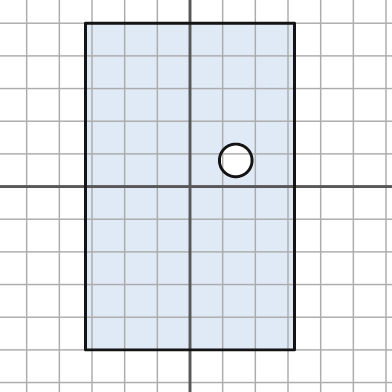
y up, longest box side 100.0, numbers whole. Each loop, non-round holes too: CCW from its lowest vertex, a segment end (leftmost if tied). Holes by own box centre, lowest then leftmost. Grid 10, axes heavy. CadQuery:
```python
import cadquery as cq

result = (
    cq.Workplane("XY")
    .moveTo(-32.0, -50.0)
    .lineTo(32.0, -50.0)
    .lineTo(32.0, 50.0)
    .lineTo(-32.0, 50.0)
    .close()
    .moveTo(14.0, 8.0)
    .circle(5.0)
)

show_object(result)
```